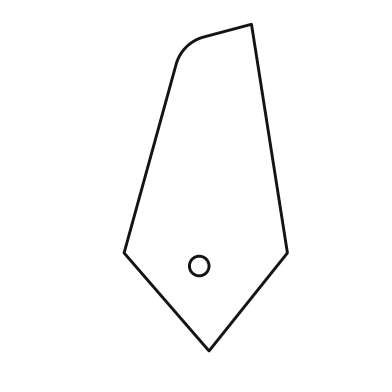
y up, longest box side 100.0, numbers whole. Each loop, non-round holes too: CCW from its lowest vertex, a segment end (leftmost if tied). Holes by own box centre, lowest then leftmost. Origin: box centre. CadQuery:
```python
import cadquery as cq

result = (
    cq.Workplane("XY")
    .moveTo(1.0, -50.0)
    .lineTo(25.0, -20.0)
    .lineTo(14.0, 50.0)
    .lineTo(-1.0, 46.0)
    .threePointArc((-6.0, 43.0), (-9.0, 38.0))
    .lineTo(-25.0, -20.0)
    .close()
    .moveTo(-2.0, -24.0)
    .circle(3.0)
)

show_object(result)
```